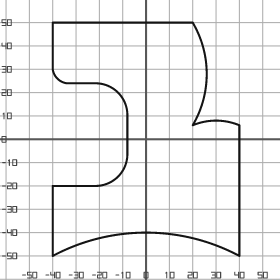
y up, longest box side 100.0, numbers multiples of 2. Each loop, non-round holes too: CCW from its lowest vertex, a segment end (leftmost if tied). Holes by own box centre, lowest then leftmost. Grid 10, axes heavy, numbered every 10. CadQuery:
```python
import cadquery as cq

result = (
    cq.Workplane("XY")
    .moveTo(-40.0, -50.0)
    .threePointArc((0.0, -40.0), (40.0, -50.0))
    .lineTo(40.0, 6.0)
    .threePointArc((30.0, 8.0), (20.0, 6.0))
    .threePointArc((26.0, 28.0), (20.0, 50.0))
    .lineTo(-40.0, 50.0)
    .lineTo(-40.0, 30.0)
    .threePointArc((-38.0, 26.0), (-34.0, 24.0))
    .lineTo(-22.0, 24.0)
    .threePointArc((-12.0, 20.0), (-8.0, 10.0))
    .lineTo(-8.0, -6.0)
    .threePointArc((-12.0, -16.0), (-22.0, -20.0))
    .lineTo(-40.0, -20.0)
    .close()
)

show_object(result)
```